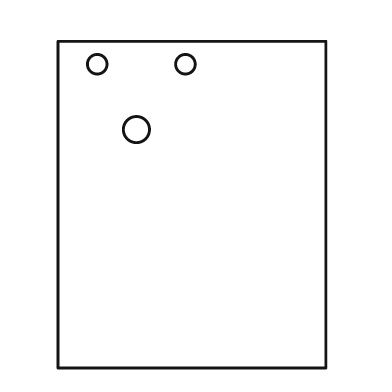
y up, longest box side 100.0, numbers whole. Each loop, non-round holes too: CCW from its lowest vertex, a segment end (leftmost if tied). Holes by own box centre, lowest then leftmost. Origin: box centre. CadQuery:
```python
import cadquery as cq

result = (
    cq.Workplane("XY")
    .moveTo(-41.0, -50.0)
    .lineTo(41.0, -50.0)
    .lineTo(41.0, 50.0)
    .lineTo(-41.0, 50.0)
    .close()
    .moveTo(-17.0, 23.0)
    .circle(4.0)
    .moveTo(-29.0, 43.0)
    .circle(3.0)
    .moveTo(-2.0, 43.0)
    .circle(3.0)
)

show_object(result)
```